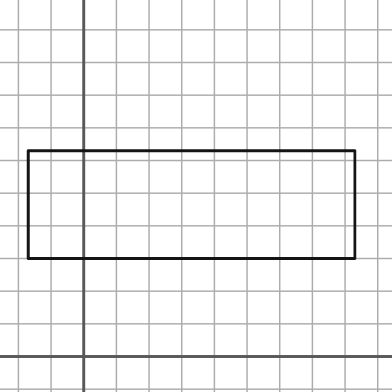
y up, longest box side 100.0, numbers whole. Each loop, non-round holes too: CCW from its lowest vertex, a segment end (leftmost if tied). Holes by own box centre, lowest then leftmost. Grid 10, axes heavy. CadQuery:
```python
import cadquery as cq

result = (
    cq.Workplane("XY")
    .moveTo(-17.0, 30.0)
    .lineTo(83.0, 30.0)
    .lineTo(83.0, 63.0)
    .lineTo(-17.0, 63.0)
    .close()
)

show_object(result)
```